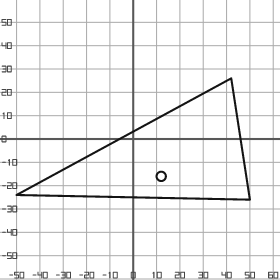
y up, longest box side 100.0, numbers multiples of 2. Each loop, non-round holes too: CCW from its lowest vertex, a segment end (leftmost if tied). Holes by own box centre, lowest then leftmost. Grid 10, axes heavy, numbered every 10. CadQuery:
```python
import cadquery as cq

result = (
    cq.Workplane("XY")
    .moveTo(50.0, -26.0)
    .lineTo(42.0, 26.0)
    .lineTo(-50.0, -24.0)
    .close()
    .moveTo(12.0, -16.0)
    .circle(2.0)
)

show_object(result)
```